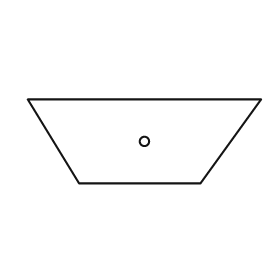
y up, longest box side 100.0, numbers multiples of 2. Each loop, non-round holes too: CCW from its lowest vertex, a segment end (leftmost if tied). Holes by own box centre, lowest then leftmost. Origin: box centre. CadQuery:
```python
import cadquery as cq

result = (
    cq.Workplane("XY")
    .moveTo(-28.0, -18.0)
    .lineTo(24.0, -18.0)
    .lineTo(50.0, 18.0)
    .lineTo(-50.0, 18.0)
    .close()
    .moveTo(0.0, 0.0)
    .circle(2.0)
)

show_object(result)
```